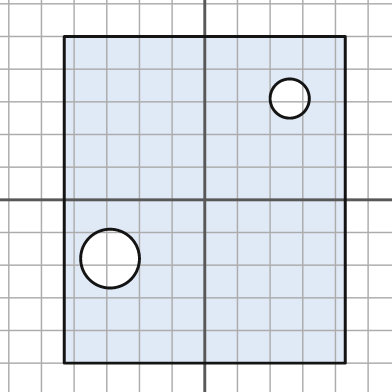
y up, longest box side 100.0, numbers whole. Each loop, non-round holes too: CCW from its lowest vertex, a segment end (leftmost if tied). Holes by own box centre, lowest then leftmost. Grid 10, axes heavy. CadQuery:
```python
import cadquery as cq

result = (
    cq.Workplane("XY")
    .moveTo(-43.0, -50.0)
    .lineTo(43.0, -50.0)
    .lineTo(43.0, 50.0)
    .lineTo(-43.0, 50.0)
    .close()
    .moveTo(-29.0, -18.0)
    .circle(9.0)
    .moveTo(26.0, 31.0)
    .circle(6.0)
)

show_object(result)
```